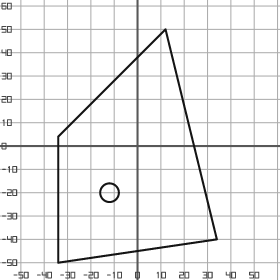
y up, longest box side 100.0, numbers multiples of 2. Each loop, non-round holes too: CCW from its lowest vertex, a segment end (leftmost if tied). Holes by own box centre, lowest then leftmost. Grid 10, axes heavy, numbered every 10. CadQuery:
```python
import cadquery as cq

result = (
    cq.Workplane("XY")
    .moveTo(-34.0, -50.0)
    .lineTo(34.0, -40.0)
    .lineTo(12.0, 50.0)
    .lineTo(-34.0, 4.0)
    .close()
    .moveTo(-12.0, -20.0)
    .circle(4.0)
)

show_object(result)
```